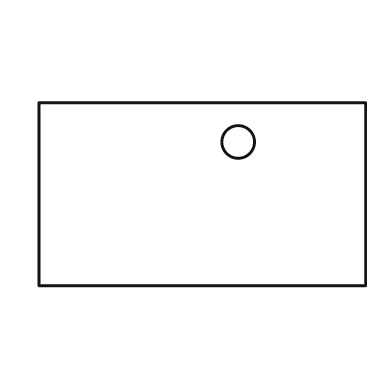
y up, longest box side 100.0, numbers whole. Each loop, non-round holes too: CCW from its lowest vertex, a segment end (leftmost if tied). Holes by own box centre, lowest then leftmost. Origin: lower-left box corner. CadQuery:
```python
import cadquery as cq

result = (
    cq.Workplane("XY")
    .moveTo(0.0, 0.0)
    .lineTo(100.0, 0.0)
    .lineTo(100.0, 56.0)
    .lineTo(0.0, 56.0)
    .close()
    .moveTo(61.0, 44.0)
    .circle(5.0)
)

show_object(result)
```